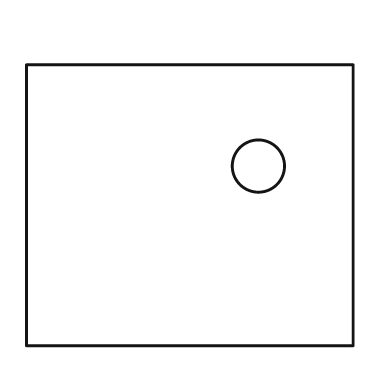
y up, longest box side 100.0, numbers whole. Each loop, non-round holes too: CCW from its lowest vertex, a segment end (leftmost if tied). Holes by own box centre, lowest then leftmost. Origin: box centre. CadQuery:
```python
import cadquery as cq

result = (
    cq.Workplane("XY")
    .moveTo(-50.0, -43.0)
    .lineTo(50.0, -43.0)
    .lineTo(50.0, 43.0)
    .lineTo(-50.0, 43.0)
    .close()
    .moveTo(21.0, 12.0)
    .circle(8.0)
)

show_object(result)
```